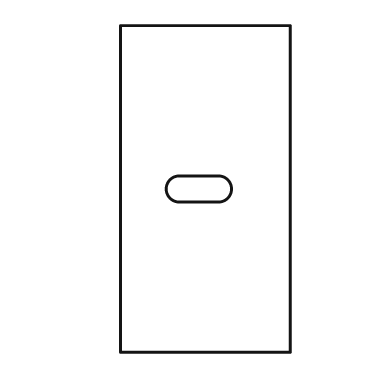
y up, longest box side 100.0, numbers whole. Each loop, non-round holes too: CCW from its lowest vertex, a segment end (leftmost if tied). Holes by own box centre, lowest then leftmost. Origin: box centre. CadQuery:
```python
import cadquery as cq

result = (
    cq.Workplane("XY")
    .moveTo(-26.0, -50.0)
    .lineTo(26.0, -50.0)
    .lineTo(26.0, 50.0)
    .lineTo(-26.0, 50.0)
    .close()
    .moveTo(-8.0, -4.0)
    .lineTo(4.0, -4.0)
    .threePointArc((8.0, 0.0), (4.0, 4.0))
    .lineTo(-8.0, 4.0)
    .threePointArc((-12.0, 0.0), (-8.0, -4.0))
    .close()
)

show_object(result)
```